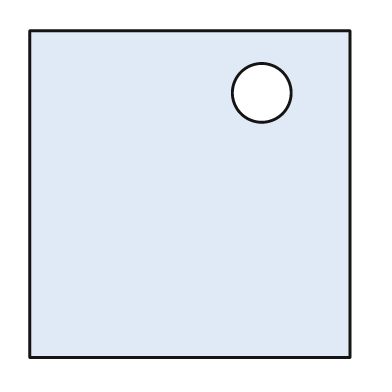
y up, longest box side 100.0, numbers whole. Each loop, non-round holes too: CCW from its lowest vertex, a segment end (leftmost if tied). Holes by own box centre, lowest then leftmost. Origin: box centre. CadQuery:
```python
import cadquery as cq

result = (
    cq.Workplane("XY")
    .moveTo(-49.0, -50.0)
    .lineTo(49.0, -50.0)
    .lineTo(49.0, 50.0)
    .lineTo(-49.0, 50.0)
    .close()
    .moveTo(22.0, 31.0)
    .circle(9.0)
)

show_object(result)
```